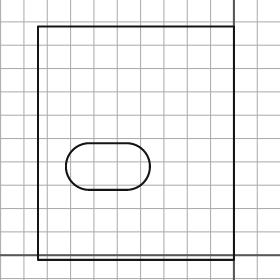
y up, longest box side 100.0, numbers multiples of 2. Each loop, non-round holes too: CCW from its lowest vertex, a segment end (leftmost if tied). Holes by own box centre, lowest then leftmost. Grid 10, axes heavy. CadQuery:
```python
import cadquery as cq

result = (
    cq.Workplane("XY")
    .moveTo(-84.0, -2.0)
    .lineTo(0.0, -2.0)
    .lineTo(0.0, 98.0)
    .lineTo(-84.0, 98.0)
    .close()
    .moveTo(-62.0, 28.0)
    .lineTo(-46.0, 28.0)
    .threePointArc((-36.0, 38.0), (-46.0, 48.0))
    .lineTo(-62.0, 48.0)
    .threePointArc((-72.0, 38.0), (-62.0, 28.0))
    .close()
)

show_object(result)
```